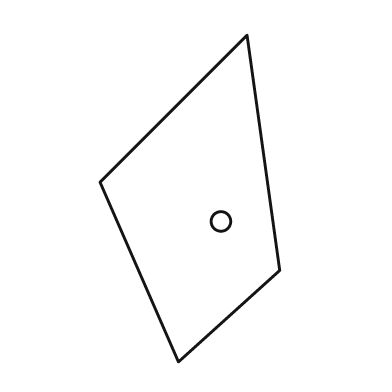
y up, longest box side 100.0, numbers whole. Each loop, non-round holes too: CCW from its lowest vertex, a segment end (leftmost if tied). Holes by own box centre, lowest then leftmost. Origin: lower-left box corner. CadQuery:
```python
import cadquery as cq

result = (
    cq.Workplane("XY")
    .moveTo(24.0, 0.0)
    .lineTo(55.0, 28.0)
    .lineTo(45.0, 100.0)
    .lineTo(0.0, 55.0)
    .close()
    .moveTo(37.0, 43.0)
    .circle(3.0)
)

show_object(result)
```